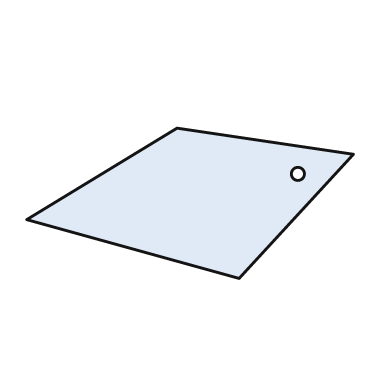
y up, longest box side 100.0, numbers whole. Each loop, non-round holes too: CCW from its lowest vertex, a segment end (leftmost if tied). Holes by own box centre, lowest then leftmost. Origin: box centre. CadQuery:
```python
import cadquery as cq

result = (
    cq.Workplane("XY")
    .moveTo(15.0, -23.0)
    .lineTo(50.0, 15.0)
    .lineTo(-4.0, 23.0)
    .lineTo(-50.0, -5.0)
    .close()
    .moveTo(33.0, 9.0)
    .circle(2.0)
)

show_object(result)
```